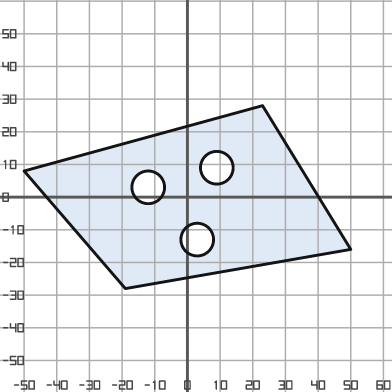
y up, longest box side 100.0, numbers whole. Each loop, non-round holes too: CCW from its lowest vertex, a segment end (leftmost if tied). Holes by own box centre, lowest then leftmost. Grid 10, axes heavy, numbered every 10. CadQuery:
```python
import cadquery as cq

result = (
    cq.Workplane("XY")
    .moveTo(-19.0, -28.0)
    .lineTo(50.0, -16.0)
    .lineTo(23.0, 28.0)
    .lineTo(-50.0, 8.0)
    .close()
    .moveTo(3.0, -13.0)
    .circle(5.0)
    .moveTo(-12.0, 3.0)
    .circle(5.0)
    .moveTo(9.0, 9.0)
    .circle(5.0)
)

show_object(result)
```